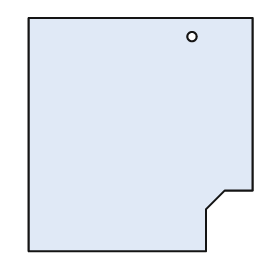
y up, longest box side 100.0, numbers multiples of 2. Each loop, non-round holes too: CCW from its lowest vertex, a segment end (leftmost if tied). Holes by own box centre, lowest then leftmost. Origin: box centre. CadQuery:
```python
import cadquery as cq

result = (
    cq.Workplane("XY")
    .moveTo(-48.0, -50.0)
    .lineTo(28.0, -50.0)
    .lineTo(28.0, -32.0)
    .lineTo(36.0, -24.0)
    .lineTo(48.0, -24.0)
    .lineTo(48.0, 50.0)
    .lineTo(-48.0, 50.0)
    .close()
    .moveTo(22.0, 42.0)
    .circle(2.0)
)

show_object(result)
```